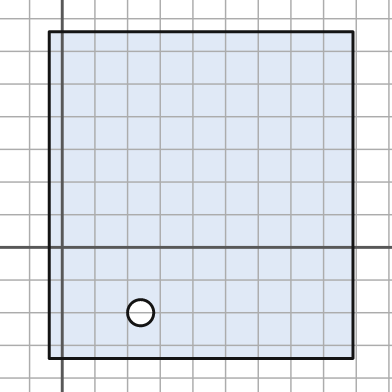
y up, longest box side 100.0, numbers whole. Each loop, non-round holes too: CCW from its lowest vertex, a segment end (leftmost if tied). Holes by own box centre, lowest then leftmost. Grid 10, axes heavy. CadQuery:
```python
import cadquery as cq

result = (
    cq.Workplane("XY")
    .moveTo(-4.0, -34.0)
    .lineTo(89.0, -34.0)
    .lineTo(89.0, 66.0)
    .lineTo(-4.0, 66.0)
    .close()
    .moveTo(24.0, -20.0)
    .circle(4.0)
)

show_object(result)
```